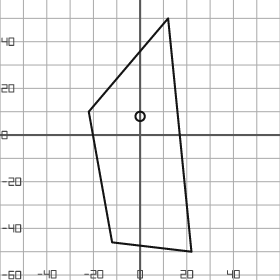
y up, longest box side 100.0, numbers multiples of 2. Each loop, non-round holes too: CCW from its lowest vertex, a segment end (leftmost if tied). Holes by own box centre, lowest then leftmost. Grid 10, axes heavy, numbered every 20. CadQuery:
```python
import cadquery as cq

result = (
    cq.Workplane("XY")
    .moveTo(22.0, -50.0)
    .lineTo(12.0, 50.0)
    .lineTo(-22.0, 10.0)
    .lineTo(-12.0, -46.0)
    .close()
    .moveTo(0.0, 8.0)
    .circle(2.0)
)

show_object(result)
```